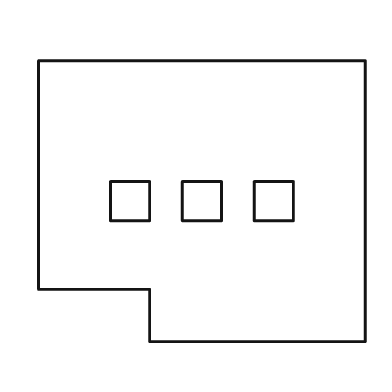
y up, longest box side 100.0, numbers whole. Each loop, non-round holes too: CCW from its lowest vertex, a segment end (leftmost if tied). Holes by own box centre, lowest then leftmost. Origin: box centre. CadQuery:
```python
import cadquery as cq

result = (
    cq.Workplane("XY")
    .moveTo(-16.0, -43.0)
    .lineTo(50.0, -43.0)
    .lineTo(50.0, 43.0)
    .lineTo(-50.0, 43.0)
    .lineTo(-50.0, -27.0)
    .lineTo(-16.0, -27.0)
    .close()
    .moveTo(-28.0, -6.0)
    .lineTo(-16.0, -6.0)
    .lineTo(-16.0, 6.0)
    .lineTo(-28.0, 6.0)
    .close()
    .moveTo(-6.0, -6.0)
    .lineTo(6.0, -6.0)
    .lineTo(6.0, 6.0)
    .lineTo(-6.0, 6.0)
    .close()
    .moveTo(16.0, -6.0)
    .lineTo(28.0, -6.0)
    .lineTo(28.0, 6.0)
    .lineTo(16.0, 6.0)
    .close()
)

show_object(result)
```